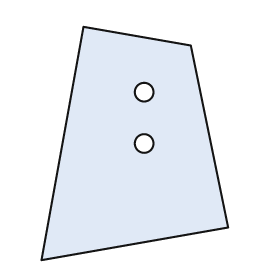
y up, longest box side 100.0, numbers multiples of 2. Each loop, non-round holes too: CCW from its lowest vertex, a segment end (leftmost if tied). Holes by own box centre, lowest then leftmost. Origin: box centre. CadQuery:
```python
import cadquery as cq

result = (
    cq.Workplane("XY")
    .moveTo(-40.0, -50.0)
    .lineTo(40.0, -36.0)
    .lineTo(24.0, 42.0)
    .lineTo(-22.0, 50.0)
    .close()
    .moveTo(4.0, 0.0)
    .circle(4.0)
    .moveTo(4.0, 22.0)
    .circle(4.0)
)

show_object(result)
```